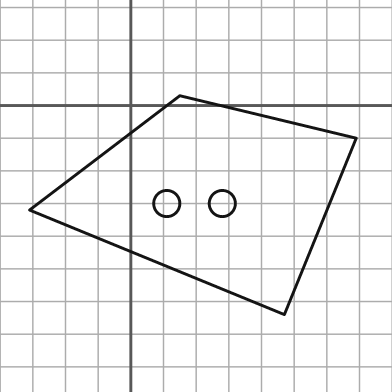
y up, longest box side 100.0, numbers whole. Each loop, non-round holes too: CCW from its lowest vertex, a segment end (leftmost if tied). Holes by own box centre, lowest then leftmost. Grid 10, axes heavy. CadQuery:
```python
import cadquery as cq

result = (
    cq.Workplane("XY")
    .moveTo(47.0, -64.0)
    .lineTo(69.0, -10.0)
    .lineTo(15.0, 3.0)
    .lineTo(-31.0, -32.0)
    .close()
    .moveTo(11.0, -30.0)
    .circle(4.0)
    .moveTo(28.0, -30.0)
    .circle(4.0)
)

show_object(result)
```